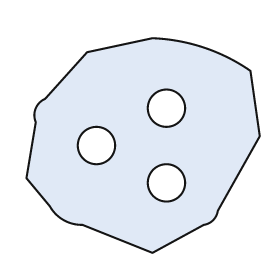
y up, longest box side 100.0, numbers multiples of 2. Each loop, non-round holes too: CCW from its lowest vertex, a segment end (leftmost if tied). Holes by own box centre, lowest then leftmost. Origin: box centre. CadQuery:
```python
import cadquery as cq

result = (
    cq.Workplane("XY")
    .moveTo(4.0, -46.0)
    .lineTo(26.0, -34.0)
    .threePointArc((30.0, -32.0), (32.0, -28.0))
    .lineTo(50.0, 4.0)
    .lineTo(46.0, 32.0)
    .threePointArc((26.0, 42.0), (4.0, 46.0))
    .lineTo(-24.0, 40.0)
    .lineTo(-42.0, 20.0)
    .threePointArc((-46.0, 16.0), (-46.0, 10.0))
    .lineTo(-50.0, -14.0)
    .lineTo(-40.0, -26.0)
    .threePointArc((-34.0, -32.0), (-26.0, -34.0))
    .close()
    .moveTo(10.0, -16.0)
    .circle(8.0)
    .moveTo(-20.0, 0.0)
    .circle(8.0)
    .moveTo(10.0, 16.0)
    .circle(8.0)
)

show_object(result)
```